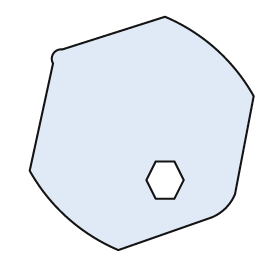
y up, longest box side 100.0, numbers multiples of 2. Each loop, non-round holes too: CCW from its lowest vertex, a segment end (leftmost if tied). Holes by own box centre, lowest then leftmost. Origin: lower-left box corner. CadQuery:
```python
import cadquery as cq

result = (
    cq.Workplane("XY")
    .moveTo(38.0, 0.0)
    .lineTo(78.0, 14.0)
    .threePointArc((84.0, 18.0), (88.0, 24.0))
    .lineTo(96.0, 66.0)
    .threePointArc((80.0, 86.0), (58.0, 100.0))
    .lineTo(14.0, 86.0)
    .threePointArc((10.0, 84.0), (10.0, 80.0))
    .lineTo(0.0, 34.0)
    .threePointArc((16.0, 14.0), (38.0, 0.0))
    .close()
    .moveTo(54.0, 22.0)
    .lineTo(62.0, 22.0)
    .lineTo(66.0, 30.0)
    .lineTo(62.0, 38.0)
    .lineTo(54.0, 38.0)
    .lineTo(50.0, 30.0)
    .close()
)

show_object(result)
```